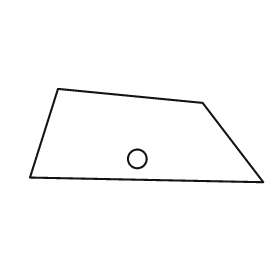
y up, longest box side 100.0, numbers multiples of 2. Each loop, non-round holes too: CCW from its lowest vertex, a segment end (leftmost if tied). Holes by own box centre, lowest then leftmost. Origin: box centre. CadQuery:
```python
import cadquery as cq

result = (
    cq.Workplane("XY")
    .moveTo(50.0, -20.0)
    .lineTo(24.0, 14.0)
    .lineTo(-38.0, 20.0)
    .lineTo(-50.0, -18.0)
    .close()
    .moveTo(-4.0, -10.0)
    .circle(4.0)
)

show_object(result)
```